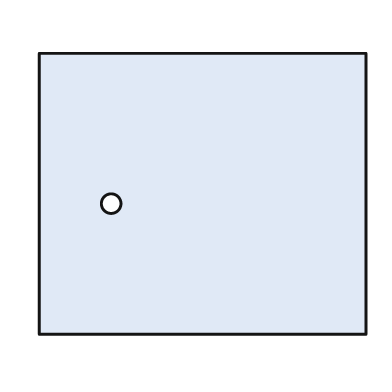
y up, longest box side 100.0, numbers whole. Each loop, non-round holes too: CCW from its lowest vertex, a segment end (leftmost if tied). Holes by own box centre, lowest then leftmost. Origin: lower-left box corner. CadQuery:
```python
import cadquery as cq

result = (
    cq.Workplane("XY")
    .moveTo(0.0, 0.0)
    .lineTo(100.0, 0.0)
    .lineTo(100.0, 86.0)
    .lineTo(0.0, 86.0)
    .close()
    .moveTo(22.0, 40.0)
    .circle(3.0)
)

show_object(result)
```